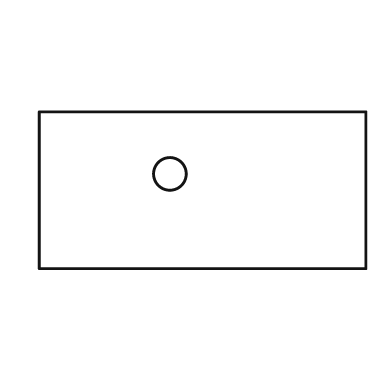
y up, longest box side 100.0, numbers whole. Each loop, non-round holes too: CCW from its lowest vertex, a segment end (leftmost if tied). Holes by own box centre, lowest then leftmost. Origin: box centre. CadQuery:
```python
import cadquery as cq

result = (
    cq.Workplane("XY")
    .moveTo(-50.0, -24.0)
    .lineTo(50.0, -24.0)
    .lineTo(50.0, 24.0)
    .lineTo(-50.0, 24.0)
    .close()
    .moveTo(-10.0, 5.0)
    .circle(5.0)
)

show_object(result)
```